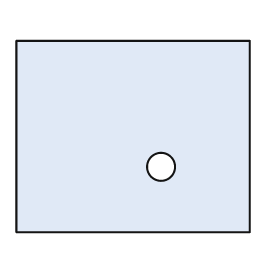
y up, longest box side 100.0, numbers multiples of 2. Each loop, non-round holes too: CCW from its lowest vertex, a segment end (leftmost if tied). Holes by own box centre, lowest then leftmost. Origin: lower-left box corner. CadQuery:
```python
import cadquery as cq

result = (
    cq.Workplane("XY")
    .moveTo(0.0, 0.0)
    .lineTo(100.0, 0.0)
    .lineTo(100.0, 82.0)
    .lineTo(0.0, 82.0)
    .close()
    .moveTo(62.0, 28.0)
    .circle(6.0)
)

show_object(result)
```